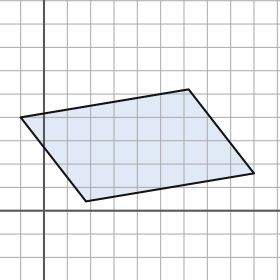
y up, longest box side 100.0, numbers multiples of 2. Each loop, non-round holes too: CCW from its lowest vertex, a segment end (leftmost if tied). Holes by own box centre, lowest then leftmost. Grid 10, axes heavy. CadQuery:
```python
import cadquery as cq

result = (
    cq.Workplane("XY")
    .moveTo(18.0, 4.0)
    .lineTo(90.0, 16.0)
    .lineTo(62.0, 52.0)
    .lineTo(-10.0, 40.0)
    .close()
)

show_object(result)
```